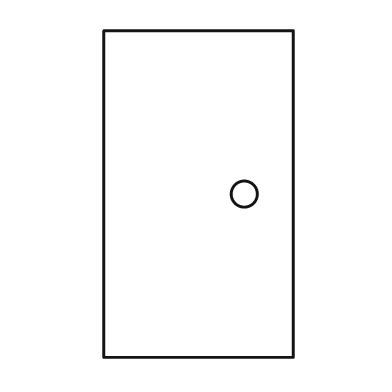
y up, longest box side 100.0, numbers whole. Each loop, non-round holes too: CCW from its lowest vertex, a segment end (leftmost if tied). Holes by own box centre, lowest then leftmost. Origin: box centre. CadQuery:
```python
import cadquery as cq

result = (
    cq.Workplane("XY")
    .moveTo(-29.0, -50.0)
    .lineTo(29.0, -50.0)
    .lineTo(29.0, 50.0)
    .lineTo(-29.0, 50.0)
    .close()
    .moveTo(14.0, 0.0)
    .circle(4.0)
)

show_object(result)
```